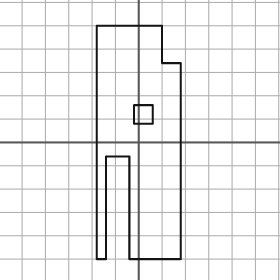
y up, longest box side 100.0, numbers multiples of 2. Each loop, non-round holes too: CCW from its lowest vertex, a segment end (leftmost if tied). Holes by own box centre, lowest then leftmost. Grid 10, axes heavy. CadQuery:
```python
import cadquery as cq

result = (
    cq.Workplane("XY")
    .moveTo(-18.0, -50.0)
    .lineTo(-14.0, -50.0)
    .lineTo(-14.0, -6.0)
    .lineTo(-4.0, -6.0)
    .lineTo(-4.0, -50.0)
    .lineTo(18.0, -50.0)
    .lineTo(18.0, 34.0)
    .lineTo(10.0, 34.0)
    .lineTo(10.0, 50.0)
    .lineTo(-18.0, 50.0)
    .close()
    .moveTo(-2.0, 8.0)
    .lineTo(6.0, 8.0)
    .lineTo(6.0, 16.0)
    .lineTo(-2.0, 16.0)
    .close()
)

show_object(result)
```